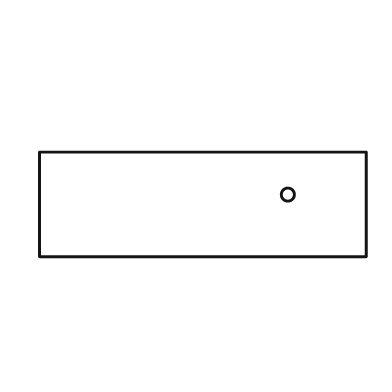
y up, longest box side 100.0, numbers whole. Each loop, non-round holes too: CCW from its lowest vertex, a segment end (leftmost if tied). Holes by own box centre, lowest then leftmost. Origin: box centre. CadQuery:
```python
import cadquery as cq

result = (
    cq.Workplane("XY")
    .moveTo(-50.0, -16.0)
    .lineTo(50.0, -16.0)
    .lineTo(50.0, 16.0)
    .lineTo(-50.0, 16.0)
    .close()
    .moveTo(26.0, 3.0)
    .circle(2.0)
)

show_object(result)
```